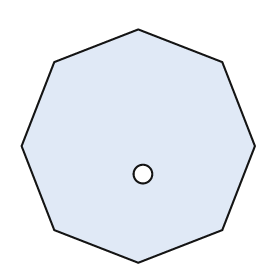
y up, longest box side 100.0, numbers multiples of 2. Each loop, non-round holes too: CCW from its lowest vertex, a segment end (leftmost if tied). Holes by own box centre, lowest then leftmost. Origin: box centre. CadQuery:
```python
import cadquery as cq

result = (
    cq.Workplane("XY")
    .moveTo(0.0, -50.0)
    .lineTo(36.0, -36.0)
    .lineTo(50.0, 0.0)
    .lineTo(36.0, 36.0)
    .lineTo(0.0, 50.0)
    .lineTo(-36.0, 36.0)
    .lineTo(-50.0, 0.0)
    .lineTo(-36.0, -36.0)
    .close()
    .moveTo(2.0, -12.0)
    .circle(4.0)
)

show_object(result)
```